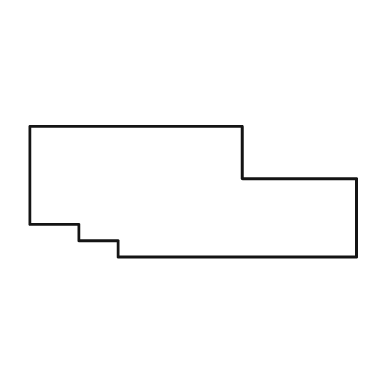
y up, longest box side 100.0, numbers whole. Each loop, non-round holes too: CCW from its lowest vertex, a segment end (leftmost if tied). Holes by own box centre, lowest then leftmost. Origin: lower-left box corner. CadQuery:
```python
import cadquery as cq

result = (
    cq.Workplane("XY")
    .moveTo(27.0, 0.0)
    .lineTo(100.0, 0.0)
    .lineTo(100.0, 24.0)
    .lineTo(65.0, 24.0)
    .lineTo(65.0, 40.0)
    .lineTo(0.0, 40.0)
    .lineTo(0.0, 10.0)
    .lineTo(15.0, 10.0)
    .lineTo(15.0, 5.0)
    .lineTo(27.0, 5.0)
    .close()
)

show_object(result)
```